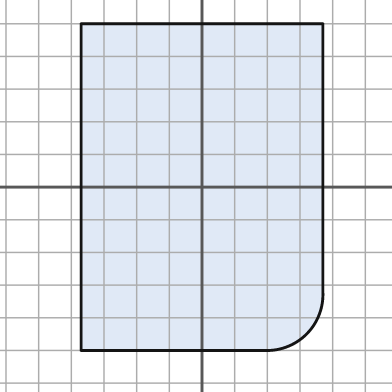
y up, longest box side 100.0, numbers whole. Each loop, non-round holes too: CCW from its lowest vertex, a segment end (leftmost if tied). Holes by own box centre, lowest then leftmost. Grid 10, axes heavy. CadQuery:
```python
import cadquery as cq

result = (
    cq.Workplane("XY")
    .moveTo(-37.0, -50.0)
    .lineTo(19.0, -50.0)
    .threePointArc((32.0, -45.0), (37.0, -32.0))
    .lineTo(37.0, 50.0)
    .lineTo(-37.0, 50.0)
    .close()
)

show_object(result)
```